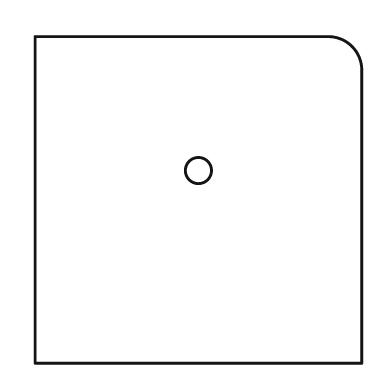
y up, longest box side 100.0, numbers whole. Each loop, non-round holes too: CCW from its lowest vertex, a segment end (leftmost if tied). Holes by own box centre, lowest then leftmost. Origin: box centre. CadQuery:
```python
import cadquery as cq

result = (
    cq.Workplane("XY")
    .moveTo(-50.0, -50.0)
    .lineTo(50.0, -50.0)
    .lineTo(50.0, 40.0)
    .threePointArc((47.0, 47.0), (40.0, 50.0))
    .lineTo(-50.0, 50.0)
    .close()
    .moveTo(0.0, 9.0)
    .circle(4.0)
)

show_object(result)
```